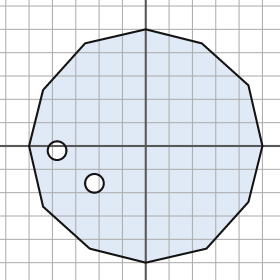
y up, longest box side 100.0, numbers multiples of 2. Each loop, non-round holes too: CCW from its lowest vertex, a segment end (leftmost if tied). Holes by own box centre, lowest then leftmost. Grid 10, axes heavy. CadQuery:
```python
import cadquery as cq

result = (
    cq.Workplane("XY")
    .moveTo(0.0, -50.0)
    .lineTo(26.0, -44.0)
    .lineTo(44.0, -24.0)
    .lineTo(50.0, 0.0)
    .lineTo(44.0, 26.0)
    .lineTo(24.0, 44.0)
    .lineTo(0.0, 50.0)
    .lineTo(-26.0, 44.0)
    .lineTo(-44.0, 24.0)
    .lineTo(-50.0, 0.0)
    .lineTo(-44.0, -26.0)
    .lineTo(-24.0, -44.0)
    .close()
    .moveTo(-22.0, -16.0)
    .circle(4.0)
    .moveTo(-38.0, -2.0)
    .circle(4.0)
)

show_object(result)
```